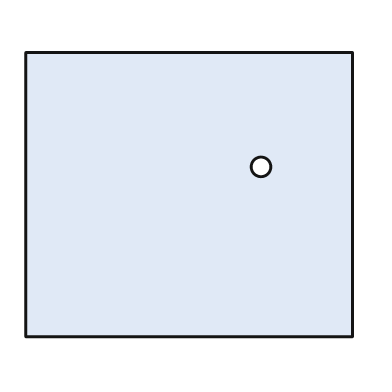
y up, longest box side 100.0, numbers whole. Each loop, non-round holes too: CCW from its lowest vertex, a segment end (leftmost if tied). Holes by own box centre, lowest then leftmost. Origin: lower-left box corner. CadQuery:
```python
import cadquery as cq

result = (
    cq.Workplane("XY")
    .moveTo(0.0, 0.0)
    .lineTo(100.0, 0.0)
    .lineTo(100.0, 87.0)
    .lineTo(0.0, 87.0)
    .close()
    .moveTo(72.0, 52.0)
    .circle(3.0)
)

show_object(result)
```